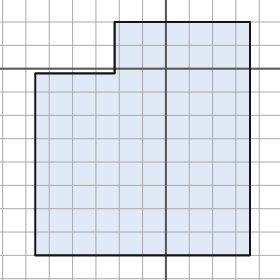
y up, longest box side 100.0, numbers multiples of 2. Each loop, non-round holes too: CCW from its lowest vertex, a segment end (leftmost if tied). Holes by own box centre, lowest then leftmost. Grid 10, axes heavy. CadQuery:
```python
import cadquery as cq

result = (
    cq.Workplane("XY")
    .moveTo(-56.0, -80.0)
    .lineTo(36.0, -80.0)
    .lineTo(36.0, 20.0)
    .lineTo(-22.0, 20.0)
    .lineTo(-22.0, -2.0)
    .lineTo(-56.0, -2.0)
    .close()
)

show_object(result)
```